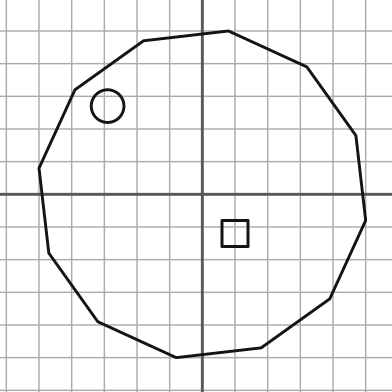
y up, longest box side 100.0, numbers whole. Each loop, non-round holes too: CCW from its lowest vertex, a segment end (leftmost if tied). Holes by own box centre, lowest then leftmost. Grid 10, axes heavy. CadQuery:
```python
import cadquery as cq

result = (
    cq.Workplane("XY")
    .moveTo(-8.0, -50.0)
    .lineTo(18.0, -47.0)
    .lineTo(39.0, -32.0)
    .lineTo(50.0, -8.0)
    .lineTo(47.0, 18.0)
    .lineTo(32.0, 39.0)
    .lineTo(8.0, 50.0)
    .lineTo(-18.0, 47.0)
    .lineTo(-39.0, 32.0)
    .lineTo(-50.0, 8.0)
    .lineTo(-47.0, -18.0)
    .lineTo(-32.0, -39.0)
    .close()
    .moveTo(6.0, -16.0)
    .lineTo(14.0, -16.0)
    .lineTo(14.0, -8.0)
    .lineTo(6.0, -8.0)
    .close()
    .moveTo(-29.0, 27.0)
    .circle(5.0)
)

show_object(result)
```